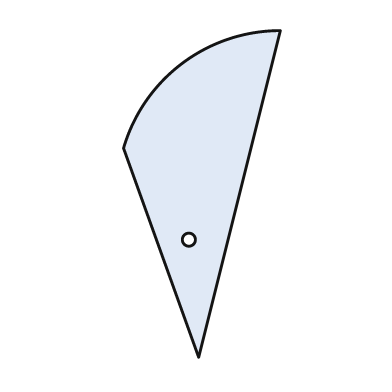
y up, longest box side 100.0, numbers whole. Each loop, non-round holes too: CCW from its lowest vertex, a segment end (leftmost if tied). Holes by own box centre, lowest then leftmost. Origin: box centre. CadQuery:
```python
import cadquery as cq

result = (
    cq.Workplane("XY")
    .moveTo(-1.0, -50.0)
    .lineTo(24.0, 50.0)
    .threePointArc((-6.0, 40.0), (-24.0, 14.0))
    .close()
    .moveTo(-4.0, -14.0)
    .circle(2.0)
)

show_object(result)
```